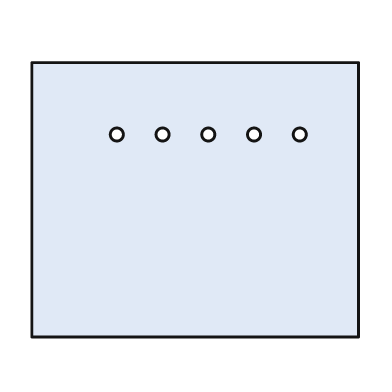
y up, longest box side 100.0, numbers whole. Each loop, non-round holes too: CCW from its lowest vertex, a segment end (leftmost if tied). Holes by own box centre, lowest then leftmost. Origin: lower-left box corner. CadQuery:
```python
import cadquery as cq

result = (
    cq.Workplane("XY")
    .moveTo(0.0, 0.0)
    .lineTo(100.0, 0.0)
    .lineTo(100.0, 84.0)
    .lineTo(0.0, 84.0)
    .close()
    .moveTo(26.0, 62.0)
    .circle(2.0)
    .moveTo(40.0, 62.0)
    .circle(2.0)
    .moveTo(54.0, 62.0)
    .circle(2.0)
    .moveTo(68.0, 62.0)
    .circle(2.0)
    .moveTo(82.0, 62.0)
    .circle(2.0)
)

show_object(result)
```